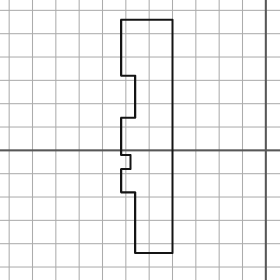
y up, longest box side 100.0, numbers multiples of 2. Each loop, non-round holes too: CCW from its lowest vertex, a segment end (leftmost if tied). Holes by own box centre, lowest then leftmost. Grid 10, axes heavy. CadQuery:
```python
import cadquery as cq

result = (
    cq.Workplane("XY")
    .moveTo(-56.0, -44.0)
    .lineTo(-40.0, -44.0)
    .lineTo(-40.0, 56.0)
    .lineTo(-62.0, 56.0)
    .lineTo(-62.0, 32.0)
    .lineTo(-56.0, 32.0)
    .lineTo(-56.0, 14.0)
    .lineTo(-62.0, 14.0)
    .lineTo(-62.0, -2.0)
    .lineTo(-58.0, -2.0)
    .lineTo(-58.0, -8.0)
    .lineTo(-62.0, -8.0)
    .lineTo(-62.0, -18.0)
    .lineTo(-56.0, -18.0)
    .close()
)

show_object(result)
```